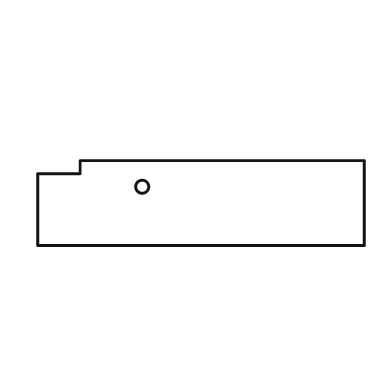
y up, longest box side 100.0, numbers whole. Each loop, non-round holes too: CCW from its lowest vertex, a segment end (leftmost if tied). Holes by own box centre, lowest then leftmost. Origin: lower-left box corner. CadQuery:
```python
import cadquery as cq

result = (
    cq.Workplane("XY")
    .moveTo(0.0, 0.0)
    .lineTo(100.0, 0.0)
    .lineTo(100.0, 26.0)
    .lineTo(13.0, 26.0)
    .lineTo(13.0, 22.0)
    .lineTo(0.0, 22.0)
    .close()
    .moveTo(32.0, 18.0)
    .circle(2.0)
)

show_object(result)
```